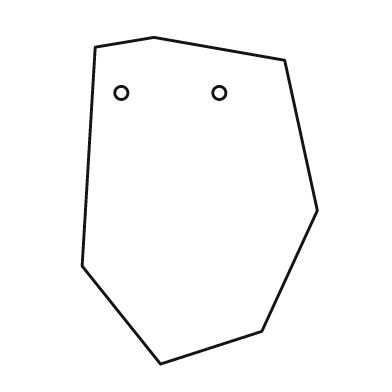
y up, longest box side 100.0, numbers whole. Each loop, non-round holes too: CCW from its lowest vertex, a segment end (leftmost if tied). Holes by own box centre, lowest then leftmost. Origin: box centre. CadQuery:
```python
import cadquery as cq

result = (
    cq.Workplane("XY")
    .moveTo(-12.0, -50.0)
    .lineTo(19.0, -40.0)
    .lineTo(36.0, -3.0)
    .lineTo(26.0, 43.0)
    .lineTo(-14.0, 50.0)
    .lineTo(-32.0, 47.0)
    .lineTo(-36.0, -20.0)
    .close()
    .moveTo(-24.0, 33.0)
    .circle(2.0)
    .moveTo(6.0, 33.0)
    .circle(2.0)
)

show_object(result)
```